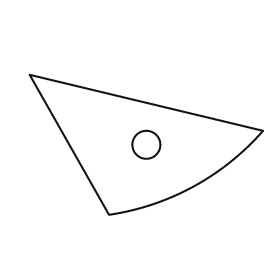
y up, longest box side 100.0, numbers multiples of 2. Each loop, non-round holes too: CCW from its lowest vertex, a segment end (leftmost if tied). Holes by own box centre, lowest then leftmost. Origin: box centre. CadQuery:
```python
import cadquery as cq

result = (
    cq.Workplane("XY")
    .moveTo(-16.0, -30.0)
    .threePointArc((20.0, -18.0), (50.0, 6.0))
    .lineTo(-50.0, 30.0)
    .close()
    .moveTo(0.0, 0.0)
    .circle(6.0)
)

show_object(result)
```